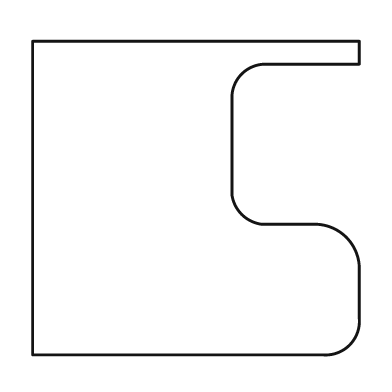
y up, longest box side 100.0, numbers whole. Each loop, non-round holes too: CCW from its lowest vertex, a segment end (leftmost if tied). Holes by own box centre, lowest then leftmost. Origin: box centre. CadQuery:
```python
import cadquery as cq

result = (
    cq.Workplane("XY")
    .moveTo(-50.0, -48.0)
    .lineTo(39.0, -48.0)
    .threePointArc((47.0, -45.0), (50.0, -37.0))
    .lineTo(50.0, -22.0)
    .threePointArc((46.0, -12.0), (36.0, -8.0))
    .lineTo(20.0, -8.0)
    .threePointArc((14.0, -5.0), (11.0, 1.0))
    .lineTo(11.0, 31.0)
    .threePointArc((14.0, 38.0), (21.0, 41.0))
    .lineTo(50.0, 41.0)
    .lineTo(50.0, 48.0)
    .lineTo(-50.0, 48.0)
    .close()
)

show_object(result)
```